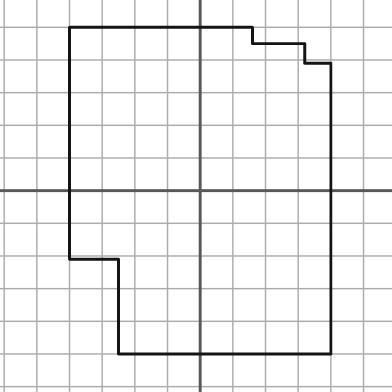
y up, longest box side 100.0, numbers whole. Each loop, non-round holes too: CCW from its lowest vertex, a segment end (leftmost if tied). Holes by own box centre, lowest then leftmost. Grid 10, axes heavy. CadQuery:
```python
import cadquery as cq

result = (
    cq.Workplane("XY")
    .moveTo(-25.0, -50.0)
    .lineTo(40.0, -50.0)
    .lineTo(40.0, 39.0)
    .lineTo(32.0, 39.0)
    .lineTo(32.0, 45.0)
    .lineTo(16.0, 45.0)
    .lineTo(16.0, 50.0)
    .lineTo(-40.0, 50.0)
    .lineTo(-40.0, -21.0)
    .lineTo(-25.0, -21.0)
    .close()
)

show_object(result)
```